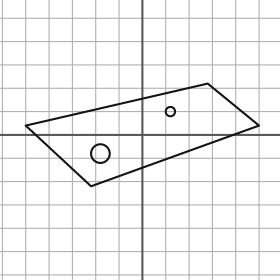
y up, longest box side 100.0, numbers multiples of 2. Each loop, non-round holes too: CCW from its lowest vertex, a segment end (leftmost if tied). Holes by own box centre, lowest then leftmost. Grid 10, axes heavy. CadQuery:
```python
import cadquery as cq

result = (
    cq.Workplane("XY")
    .moveTo(-22.0, -22.0)
    .lineTo(50.0, 4.0)
    .lineTo(28.0, 22.0)
    .lineTo(-50.0, 4.0)
    .close()
    .moveTo(-18.0, -8.0)
    .circle(4.0)
    .moveTo(12.0, 10.0)
    .circle(2.0)
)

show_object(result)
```